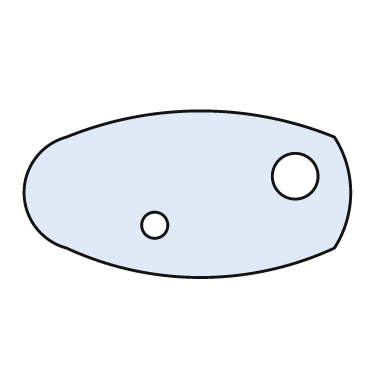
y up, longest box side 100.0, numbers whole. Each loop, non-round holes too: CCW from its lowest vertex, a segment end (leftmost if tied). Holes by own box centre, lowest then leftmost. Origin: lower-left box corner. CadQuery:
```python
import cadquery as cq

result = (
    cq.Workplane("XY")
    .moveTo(13.0, 9.0)
    .threePointArc((54.0, 0.0), (95.0, 9.0))
    .threePointArc((100.0, 26.0), (95.0, 43.0))
    .threePointArc((54.0, 51.0), (13.0, 43.0))
    .threePointArc((0.0, 26.0), (13.0, 9.0))
    .close()
    .moveTo(40.0, 16.0)
    .circle(4.0)
    .moveTo(83.0, 31.0)
    .circle(7.0)
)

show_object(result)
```